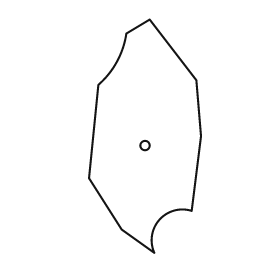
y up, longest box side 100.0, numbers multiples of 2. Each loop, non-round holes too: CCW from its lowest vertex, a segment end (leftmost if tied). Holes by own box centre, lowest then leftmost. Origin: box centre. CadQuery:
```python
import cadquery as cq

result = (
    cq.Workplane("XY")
    .moveTo(4.0, -50.0)
    .threePointArc((6.0, -36.0), (20.0, -32.0))
    .lineTo(24.0, 0.0)
    .lineTo(22.0, 24.0)
    .lineTo(2.0, 50.0)
    .lineTo(-8.0, 44.0)
    .threePointArc((-12.0, 32.0), (-20.0, 22.0))
    .lineTo(-24.0, -18.0)
    .lineTo(-10.0, -40.0)
    .close()
    .moveTo(0.0, -4.0)
    .circle(2.0)
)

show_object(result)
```